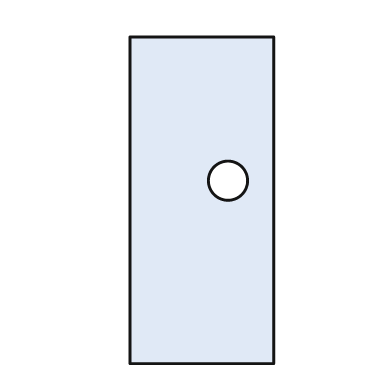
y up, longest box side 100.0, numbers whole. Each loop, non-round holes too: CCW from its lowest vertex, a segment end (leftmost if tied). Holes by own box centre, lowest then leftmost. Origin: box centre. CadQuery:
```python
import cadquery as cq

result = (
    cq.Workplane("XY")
    .moveTo(-22.0, -50.0)
    .lineTo(22.0, -50.0)
    .lineTo(22.0, 50.0)
    .lineTo(-22.0, 50.0)
    .close()
    .moveTo(8.0, 6.0)
    .circle(6.0)
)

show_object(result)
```